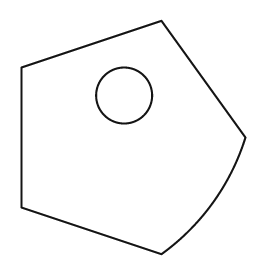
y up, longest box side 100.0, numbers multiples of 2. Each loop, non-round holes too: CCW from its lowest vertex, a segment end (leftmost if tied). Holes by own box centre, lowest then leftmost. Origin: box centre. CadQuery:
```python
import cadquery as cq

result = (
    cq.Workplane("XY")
    .moveTo(12.0, -50.0)
    .threePointArc((34.0, -28.0), (48.0, 0.0))
    .lineTo(12.0, 50.0)
    .lineTo(-48.0, 30.0)
    .lineTo(-48.0, -30.0)
    .close()
    .moveTo(-4.0, 18.0)
    .circle(12.0)
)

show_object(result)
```